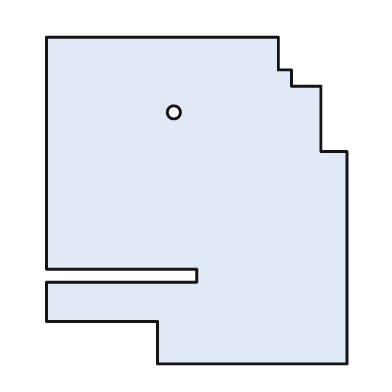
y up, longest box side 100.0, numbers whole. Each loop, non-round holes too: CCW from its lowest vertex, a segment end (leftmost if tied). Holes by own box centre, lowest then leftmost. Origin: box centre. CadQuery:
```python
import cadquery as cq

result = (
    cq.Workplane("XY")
    .moveTo(-12.0, -50.0)
    .lineTo(46.0, -50.0)
    .lineTo(46.0, 15.0)
    .lineTo(38.0, 15.0)
    .lineTo(38.0, 35.0)
    .lineTo(29.0, 35.0)
    .lineTo(29.0, 40.0)
    .lineTo(25.0, 40.0)
    .lineTo(25.0, 50.0)
    .lineTo(-46.0, 50.0)
    .lineTo(-46.0, -21.0)
    .lineTo(0.0, -21.0)
    .lineTo(0.0, -25.0)
    .lineTo(-46.0, -25.0)
    .lineTo(-46.0, -37.0)
    .lineTo(-12.0, -37.0)
    .close()
    .moveTo(-7.0, 27.0)
    .circle(2.0)
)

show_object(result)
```